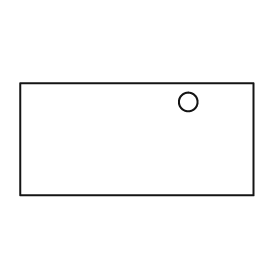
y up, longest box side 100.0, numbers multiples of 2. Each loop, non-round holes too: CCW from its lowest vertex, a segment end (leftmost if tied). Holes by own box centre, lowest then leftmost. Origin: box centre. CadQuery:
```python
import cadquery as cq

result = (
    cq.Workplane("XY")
    .moveTo(-50.0, -24.0)
    .lineTo(50.0, -24.0)
    .lineTo(50.0, 24.0)
    .lineTo(-50.0, 24.0)
    .close()
    .moveTo(22.0, 16.0)
    .circle(4.0)
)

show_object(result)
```